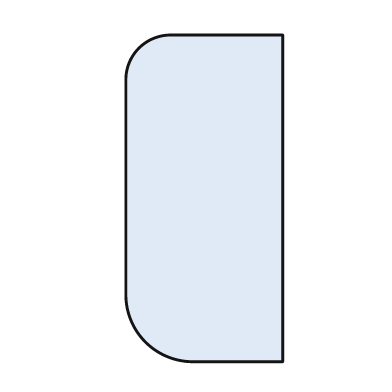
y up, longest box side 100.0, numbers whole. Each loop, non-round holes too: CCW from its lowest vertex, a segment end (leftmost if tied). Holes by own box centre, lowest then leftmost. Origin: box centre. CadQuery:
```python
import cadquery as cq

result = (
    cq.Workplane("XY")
    .moveTo(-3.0, -50.0)
    .lineTo(24.0, -50.0)
    .lineTo(24.0, 50.0)
    .lineTo(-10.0, 50.0)
    .threePointArc((-20.0, 46.0), (-24.0, 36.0))
    .lineTo(-24.0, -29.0)
    .threePointArc((-18.0, -44.0), (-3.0, -50.0))
    .close()
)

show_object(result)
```